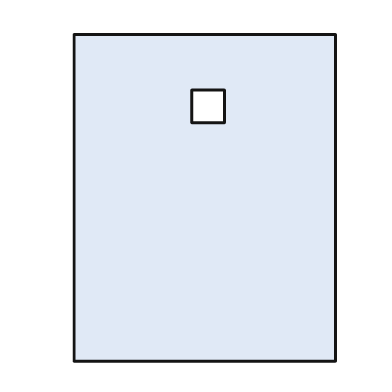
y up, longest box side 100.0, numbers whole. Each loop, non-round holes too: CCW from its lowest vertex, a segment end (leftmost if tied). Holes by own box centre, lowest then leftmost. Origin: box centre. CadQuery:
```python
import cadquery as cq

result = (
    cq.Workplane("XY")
    .moveTo(-40.0, -50.0)
    .lineTo(40.0, -50.0)
    .lineTo(40.0, 50.0)
    .lineTo(-40.0, 50.0)
    .close()
    .moveTo(-4.0, 23.0)
    .lineTo(6.0, 23.0)
    .lineTo(6.0, 33.0)
    .lineTo(-4.0, 33.0)
    .close()
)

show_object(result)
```